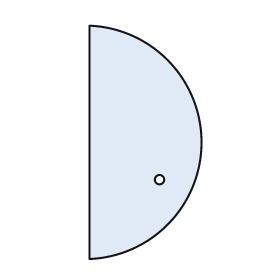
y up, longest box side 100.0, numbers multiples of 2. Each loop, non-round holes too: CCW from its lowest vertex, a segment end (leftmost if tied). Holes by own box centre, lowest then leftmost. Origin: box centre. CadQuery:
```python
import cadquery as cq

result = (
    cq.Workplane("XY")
    .moveTo(-24.0, -50.0)
    .threePointArc((24.0, 0.0), (-24.0, 50.0))
    .close()
    .moveTo(6.0, -16.0)
    .circle(2.0)
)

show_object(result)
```